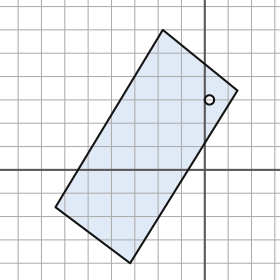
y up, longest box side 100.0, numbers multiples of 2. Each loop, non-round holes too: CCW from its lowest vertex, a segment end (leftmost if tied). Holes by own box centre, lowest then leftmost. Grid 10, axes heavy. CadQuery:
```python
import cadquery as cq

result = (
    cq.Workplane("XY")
    .moveTo(-32.0, -40.0)
    .lineTo(14.0, 34.0)
    .lineTo(-18.0, 60.0)
    .lineTo(-64.0, -16.0)
    .close()
    .moveTo(2.0, 30.0)
    .circle(2.0)
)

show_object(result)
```